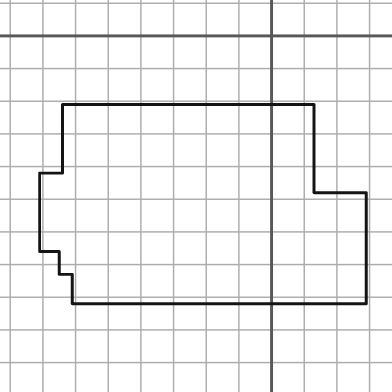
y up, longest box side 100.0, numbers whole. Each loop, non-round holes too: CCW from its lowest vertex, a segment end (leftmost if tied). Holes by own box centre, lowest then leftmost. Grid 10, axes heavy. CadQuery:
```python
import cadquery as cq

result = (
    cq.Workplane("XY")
    .moveTo(-61.0, -82.0)
    .lineTo(29.0, -82.0)
    .lineTo(29.0, -48.0)
    .lineTo(13.0, -48.0)
    .lineTo(13.0, -21.0)
    .lineTo(-64.0, -21.0)
    .lineTo(-64.0, -42.0)
    .lineTo(-71.0, -42.0)
    .lineTo(-71.0, -66.0)
    .lineTo(-65.0, -66.0)
    .lineTo(-65.0, -73.0)
    .lineTo(-61.0, -73.0)
    .close()
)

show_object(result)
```